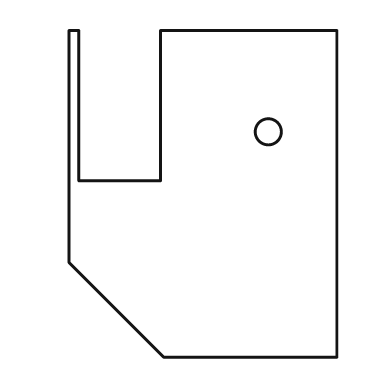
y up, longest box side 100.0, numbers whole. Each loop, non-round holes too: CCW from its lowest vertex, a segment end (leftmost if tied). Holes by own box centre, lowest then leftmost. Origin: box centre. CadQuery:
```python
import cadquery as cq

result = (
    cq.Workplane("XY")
    .moveTo(-12.0, -50.0)
    .lineTo(41.0, -50.0)
    .lineTo(41.0, 50.0)
    .lineTo(-13.0, 50.0)
    .lineTo(-13.0, 4.0)
    .lineTo(-38.0, 4.0)
    .lineTo(-38.0, 50.0)
    .lineTo(-41.0, 50.0)
    .lineTo(-41.0, -21.0)
    .close()
    .moveTo(20.0, 19.0)
    .circle(4.0)
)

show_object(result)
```